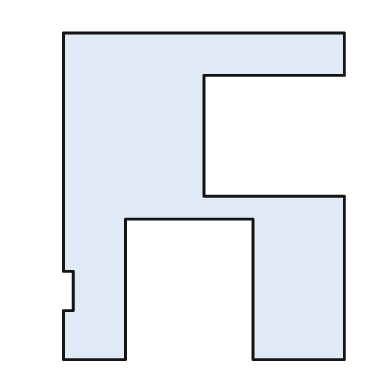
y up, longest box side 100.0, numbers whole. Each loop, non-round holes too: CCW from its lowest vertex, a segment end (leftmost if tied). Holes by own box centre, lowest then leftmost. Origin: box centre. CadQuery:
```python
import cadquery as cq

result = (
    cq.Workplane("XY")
    .moveTo(-43.0, -50.0)
    .lineTo(-24.0, -50.0)
    .lineTo(-24.0, -7.0)
    .lineTo(15.0, -7.0)
    .lineTo(15.0, -50.0)
    .lineTo(43.0, -50.0)
    .lineTo(43.0, 0.0)
    .lineTo(0.0, 0.0)
    .lineTo(0.0, 37.0)
    .lineTo(43.0, 37.0)
    .lineTo(43.0, 50.0)
    .lineTo(-43.0, 50.0)
    .lineTo(-43.0, -23.0)
    .lineTo(-40.0, -23.0)
    .lineTo(-40.0, -35.0)
    .lineTo(-43.0, -35.0)
    .close()
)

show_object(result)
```